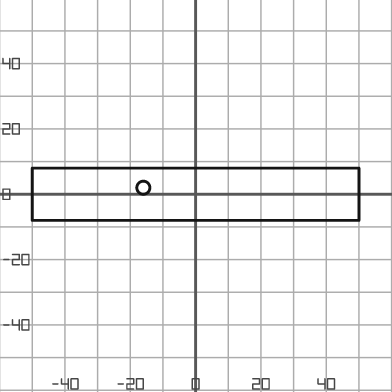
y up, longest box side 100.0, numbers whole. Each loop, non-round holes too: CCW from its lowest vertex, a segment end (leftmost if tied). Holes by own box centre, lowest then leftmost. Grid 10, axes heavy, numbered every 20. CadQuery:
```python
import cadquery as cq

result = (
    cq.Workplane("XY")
    .moveTo(-50.0, -8.0)
    .lineTo(50.0, -8.0)
    .lineTo(50.0, 8.0)
    .lineTo(-50.0, 8.0)
    .close()
    .moveTo(-16.0, 2.0)
    .circle(2.0)
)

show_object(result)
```